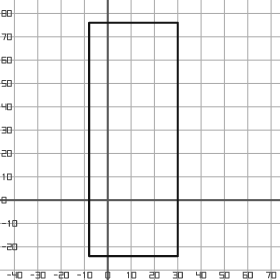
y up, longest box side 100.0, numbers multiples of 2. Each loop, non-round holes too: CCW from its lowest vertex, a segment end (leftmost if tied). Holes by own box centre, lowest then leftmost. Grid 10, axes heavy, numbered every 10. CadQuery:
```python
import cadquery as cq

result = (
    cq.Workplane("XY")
    .moveTo(-8.0, -24.0)
    .lineTo(30.0, -24.0)
    .lineTo(30.0, 76.0)
    .lineTo(-8.0, 76.0)
    .close()
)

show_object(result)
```